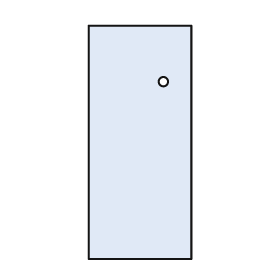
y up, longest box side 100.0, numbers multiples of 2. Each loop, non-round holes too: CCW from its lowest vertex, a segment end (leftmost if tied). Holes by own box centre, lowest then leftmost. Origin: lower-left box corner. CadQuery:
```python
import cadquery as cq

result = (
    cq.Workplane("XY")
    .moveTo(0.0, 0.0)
    .lineTo(44.0, 0.0)
    .lineTo(44.0, 100.0)
    .lineTo(0.0, 100.0)
    .close()
    .moveTo(32.0, 76.0)
    .circle(2.0)
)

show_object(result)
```